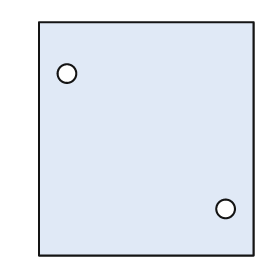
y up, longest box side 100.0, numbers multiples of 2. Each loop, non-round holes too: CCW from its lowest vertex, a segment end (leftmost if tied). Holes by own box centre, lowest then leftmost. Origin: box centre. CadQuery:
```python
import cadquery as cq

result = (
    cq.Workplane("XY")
    .moveTo(-46.0, -50.0)
    .lineTo(46.0, -50.0)
    .lineTo(46.0, 50.0)
    .lineTo(-46.0, 50.0)
    .close()
    .moveTo(34.0, -30.0)
    .circle(4.0)
    .moveTo(-34.0, 28.0)
    .circle(4.0)
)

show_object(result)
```